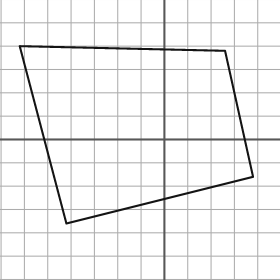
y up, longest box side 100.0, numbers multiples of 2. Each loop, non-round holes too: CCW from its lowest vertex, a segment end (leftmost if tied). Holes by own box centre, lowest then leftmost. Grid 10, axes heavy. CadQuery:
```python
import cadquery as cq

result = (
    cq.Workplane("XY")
    .moveTo(-42.0, -36.0)
    .lineTo(38.0, -16.0)
    .lineTo(26.0, 38.0)
    .lineTo(-62.0, 40.0)
    .close()
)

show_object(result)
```